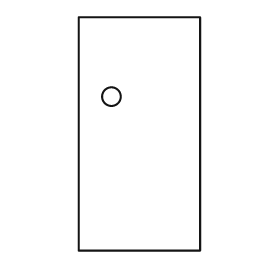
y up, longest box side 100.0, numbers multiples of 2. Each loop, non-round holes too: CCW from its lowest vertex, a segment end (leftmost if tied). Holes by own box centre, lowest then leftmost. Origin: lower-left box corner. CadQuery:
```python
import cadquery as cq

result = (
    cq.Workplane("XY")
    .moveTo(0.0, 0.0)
    .lineTo(52.0, 0.0)
    .lineTo(52.0, 100.0)
    .lineTo(0.0, 100.0)
    .close()
    .moveTo(14.0, 66.0)
    .circle(4.0)
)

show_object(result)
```